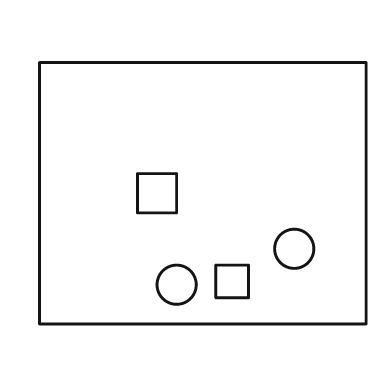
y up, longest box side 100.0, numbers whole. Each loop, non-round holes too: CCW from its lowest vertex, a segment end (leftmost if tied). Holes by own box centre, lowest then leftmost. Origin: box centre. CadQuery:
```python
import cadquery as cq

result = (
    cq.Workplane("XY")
    .moveTo(-50.0, -40.0)
    .lineTo(50.0, -40.0)
    .lineTo(50.0, 40.0)
    .lineTo(-50.0, 40.0)
    .close()
    .moveTo(-8.0, -28.0)
    .circle(6.0)
    .moveTo(4.0, -32.0)
    .lineTo(14.0, -32.0)
    .lineTo(14.0, -22.0)
    .lineTo(4.0, -22.0)
    .close()
    .moveTo(28.0, -17.0)
    .circle(6.0)
    .moveTo(-20.0, -6.0)
    .lineTo(-8.0, -6.0)
    .lineTo(-8.0, 6.0)
    .lineTo(-20.0, 6.0)
    .close()
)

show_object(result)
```